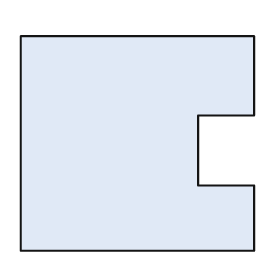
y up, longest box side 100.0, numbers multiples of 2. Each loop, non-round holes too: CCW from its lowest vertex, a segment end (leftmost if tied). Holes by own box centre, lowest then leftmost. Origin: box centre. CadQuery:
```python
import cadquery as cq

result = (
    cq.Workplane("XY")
    .moveTo(-50.0, -46.0)
    .lineTo(50.0, -46.0)
    .lineTo(50.0, -18.0)
    .lineTo(26.0, -18.0)
    .lineTo(26.0, 12.0)
    .lineTo(50.0, 12.0)
    .lineTo(50.0, 46.0)
    .lineTo(-50.0, 46.0)
    .close()
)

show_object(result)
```